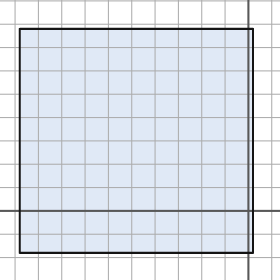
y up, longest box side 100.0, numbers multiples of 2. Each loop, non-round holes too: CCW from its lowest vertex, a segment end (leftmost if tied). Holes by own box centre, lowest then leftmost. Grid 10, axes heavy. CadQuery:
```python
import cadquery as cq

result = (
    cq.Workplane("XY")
    .moveTo(-98.0, -18.0)
    .lineTo(2.0, -18.0)
    .lineTo(2.0, 78.0)
    .lineTo(-98.0, 78.0)
    .close()
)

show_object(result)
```